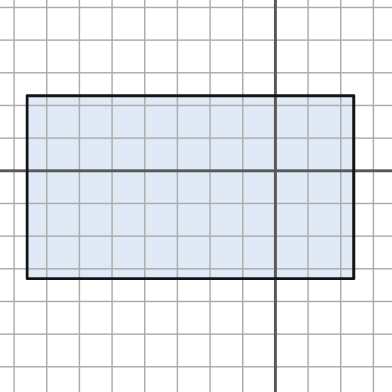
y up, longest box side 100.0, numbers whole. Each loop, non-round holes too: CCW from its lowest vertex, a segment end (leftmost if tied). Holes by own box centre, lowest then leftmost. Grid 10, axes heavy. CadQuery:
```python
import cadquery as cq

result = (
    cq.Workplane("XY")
    .moveTo(-76.0, -33.0)
    .lineTo(24.0, -33.0)
    .lineTo(24.0, 23.0)
    .lineTo(-76.0, 23.0)
    .close()
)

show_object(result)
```